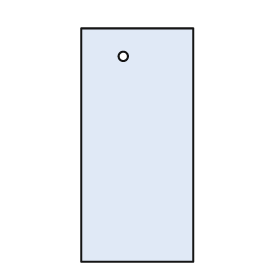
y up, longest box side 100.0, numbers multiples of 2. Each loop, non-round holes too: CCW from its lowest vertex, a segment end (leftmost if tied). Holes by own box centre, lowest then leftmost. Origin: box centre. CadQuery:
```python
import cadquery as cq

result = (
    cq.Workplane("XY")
    .moveTo(-24.0, -50.0)
    .lineTo(24.0, -50.0)
    .lineTo(24.0, 50.0)
    .lineTo(-24.0, 50.0)
    .close()
    .moveTo(-6.0, 38.0)
    .circle(2.0)
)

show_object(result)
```